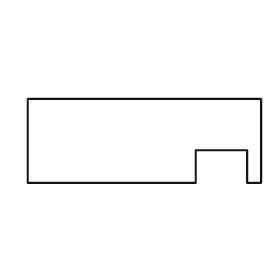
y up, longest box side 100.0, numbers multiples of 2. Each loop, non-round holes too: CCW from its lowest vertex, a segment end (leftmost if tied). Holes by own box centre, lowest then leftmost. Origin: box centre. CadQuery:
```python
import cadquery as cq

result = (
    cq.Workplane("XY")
    .moveTo(-50.0, -18.0)
    .lineTo(22.0, -18.0)
    .lineTo(22.0, -4.0)
    .lineTo(44.0, -4.0)
    .lineTo(44.0, -18.0)
    .lineTo(50.0, -18.0)
    .lineTo(50.0, 18.0)
    .lineTo(-50.0, 18.0)
    .close()
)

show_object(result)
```